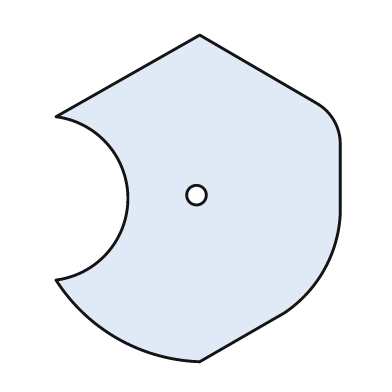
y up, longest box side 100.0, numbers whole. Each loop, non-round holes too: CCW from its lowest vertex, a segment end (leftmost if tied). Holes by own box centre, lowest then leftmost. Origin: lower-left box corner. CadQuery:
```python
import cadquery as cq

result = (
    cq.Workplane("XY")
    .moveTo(44.0, 0.0)
    .lineTo(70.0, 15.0)
    .threePointArc((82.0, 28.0), (87.0, 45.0))
    .lineTo(87.0, 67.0)
    .threePointArc((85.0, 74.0), (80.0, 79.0))
    .lineTo(44.0, 100.0)
    .lineTo(0.0, 75.0)
    .threePointArc((22.0, 50.0), (0.0, 25.0))
    .threePointArc((19.0, 7.0), (44.0, 0.0))
    .close()
    .moveTo(43.0, 51.0)
    .circle(3.0)
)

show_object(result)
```